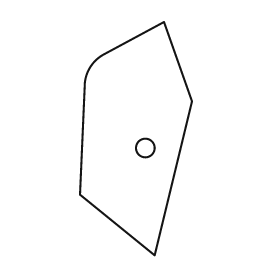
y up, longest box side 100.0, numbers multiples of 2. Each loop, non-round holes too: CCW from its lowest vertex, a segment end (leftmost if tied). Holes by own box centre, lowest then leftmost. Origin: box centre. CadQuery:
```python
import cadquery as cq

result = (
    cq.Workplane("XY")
    .moveTo(8.0, -50.0)
    .lineTo(24.0, 16.0)
    .lineTo(12.0, 50.0)
    .lineTo(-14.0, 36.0)
    .threePointArc((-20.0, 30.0), (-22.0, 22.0))
    .lineTo(-24.0, -24.0)
    .close()
    .moveTo(4.0, -4.0)
    .circle(4.0)
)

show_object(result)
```